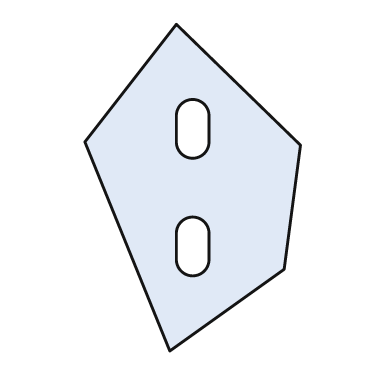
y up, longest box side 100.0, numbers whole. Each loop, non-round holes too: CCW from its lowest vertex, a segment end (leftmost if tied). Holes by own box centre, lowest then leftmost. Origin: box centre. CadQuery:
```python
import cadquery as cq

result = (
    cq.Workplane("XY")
    .moveTo(-7.0, -50.0)
    .lineTo(28.0, -25.0)
    .lineTo(33.0, 13.0)
    .lineTo(-5.0, 50.0)
    .lineTo(-33.0, 14.0)
    .close()
    .moveTo(-5.0, -22.0)
    .threePointArc((0.0, -27.0), (5.0, -22.0))
    .lineTo(5.0, -14.0)
    .threePointArc((0.0, -9.0), (-5.0, -14.0))
    .close()
    .moveTo(-5.0, 14.0)
    .threePointArc((0.0, 9.0), (5.0, 14.0))
    .lineTo(5.0, 22.0)
    .threePointArc((0.0, 27.0), (-5.0, 22.0))
    .close()
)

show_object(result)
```